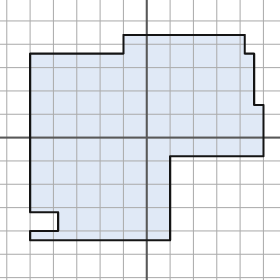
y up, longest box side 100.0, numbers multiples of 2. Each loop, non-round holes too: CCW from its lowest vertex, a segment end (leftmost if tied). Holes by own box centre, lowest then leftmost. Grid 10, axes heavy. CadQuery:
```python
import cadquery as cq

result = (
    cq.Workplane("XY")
    .moveTo(-50.0, -44.0)
    .lineTo(10.0, -44.0)
    .lineTo(10.0, -8.0)
    .lineTo(50.0, -8.0)
    .lineTo(50.0, 14.0)
    .lineTo(46.0, 14.0)
    .lineTo(46.0, 36.0)
    .lineTo(42.0, 36.0)
    .lineTo(42.0, 44.0)
    .lineTo(-10.0, 44.0)
    .lineTo(-10.0, 36.0)
    .lineTo(-50.0, 36.0)
    .lineTo(-50.0, -32.0)
    .lineTo(-38.0, -32.0)
    .lineTo(-38.0, -40.0)
    .lineTo(-50.0, -40.0)
    .close()
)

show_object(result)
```